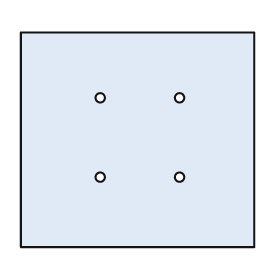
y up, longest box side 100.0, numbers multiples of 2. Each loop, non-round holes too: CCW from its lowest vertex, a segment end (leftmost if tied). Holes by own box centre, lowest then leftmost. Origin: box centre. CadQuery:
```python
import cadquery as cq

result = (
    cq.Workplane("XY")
    .moveTo(-50.0, -46.0)
    .lineTo(50.0, -46.0)
    .lineTo(50.0, 46.0)
    .lineTo(-50.0, 46.0)
    .close()
    .moveTo(-16.0, -16.0)
    .circle(2.0)
    .moveTo(18.0, -16.0)
    .circle(2.0)
    .moveTo(-16.0, 18.0)
    .circle(2.0)
    .moveTo(18.0, 18.0)
    .circle(2.0)
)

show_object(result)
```